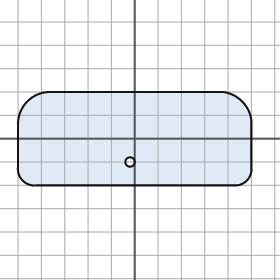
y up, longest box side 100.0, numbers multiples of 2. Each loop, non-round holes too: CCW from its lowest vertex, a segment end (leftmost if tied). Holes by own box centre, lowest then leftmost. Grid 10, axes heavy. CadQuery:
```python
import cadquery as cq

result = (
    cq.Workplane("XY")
    .moveTo(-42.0, -20.0)
    .lineTo(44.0, -20.0)
    .threePointArc((48.0, -18.0), (50.0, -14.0))
    .lineTo(50.0, 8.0)
    .threePointArc((46.0, 16.0), (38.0, 20.0))
    .lineTo(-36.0, 20.0)
    .threePointArc((-46.0, 16.0), (-50.0, 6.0))
    .lineTo(-50.0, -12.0)
    .threePointArc((-48.0, -18.0), (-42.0, -20.0))
    .close()
    .moveTo(-2.0, -10.0)
    .circle(2.0)
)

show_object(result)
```